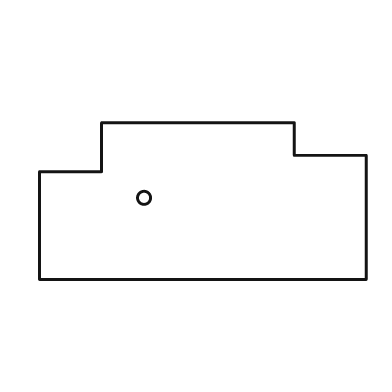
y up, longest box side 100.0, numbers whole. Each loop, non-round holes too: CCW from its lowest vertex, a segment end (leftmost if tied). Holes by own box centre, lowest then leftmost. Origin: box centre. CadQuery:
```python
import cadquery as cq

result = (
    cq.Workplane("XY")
    .moveTo(-50.0, -24.0)
    .lineTo(50.0, -24.0)
    .lineTo(50.0, 14.0)
    .lineTo(28.0, 14.0)
    .lineTo(28.0, 24.0)
    .lineTo(-31.0, 24.0)
    .lineTo(-31.0, 9.0)
    .lineTo(-50.0, 9.0)
    .close()
    .moveTo(-18.0, 1.0)
    .circle(2.0)
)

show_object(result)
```